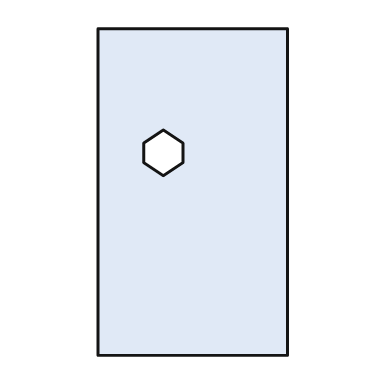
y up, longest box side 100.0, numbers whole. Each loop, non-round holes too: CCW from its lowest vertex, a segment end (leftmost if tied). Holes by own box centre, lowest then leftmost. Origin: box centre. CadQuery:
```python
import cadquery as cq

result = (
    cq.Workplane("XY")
    .moveTo(-29.0, -50.0)
    .lineTo(29.0, -50.0)
    .lineTo(29.0, 50.0)
    .lineTo(-29.0, 50.0)
    .close()
    .moveTo(-9.0, 5.0)
    .lineTo(-3.0, 9.0)
    .lineTo(-3.0, 15.0)
    .lineTo(-9.0, 19.0)
    .lineTo(-15.0, 15.0)
    .lineTo(-15.0, 9.0)
    .close()
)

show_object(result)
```